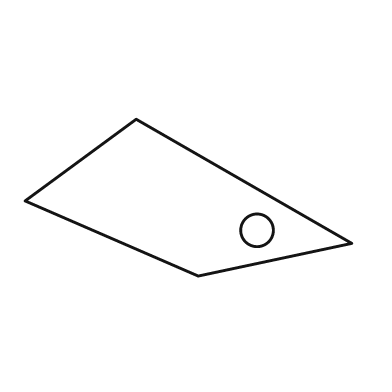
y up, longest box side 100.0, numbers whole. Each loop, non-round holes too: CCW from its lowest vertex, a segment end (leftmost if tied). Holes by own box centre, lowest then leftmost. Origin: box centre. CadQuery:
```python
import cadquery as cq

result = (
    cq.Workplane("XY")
    .moveTo(3.0, -24.0)
    .lineTo(50.0, -14.0)
    .lineTo(-16.0, 24.0)
    .lineTo(-50.0, -1.0)
    .close()
    .moveTo(21.0, -10.0)
    .circle(5.0)
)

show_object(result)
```